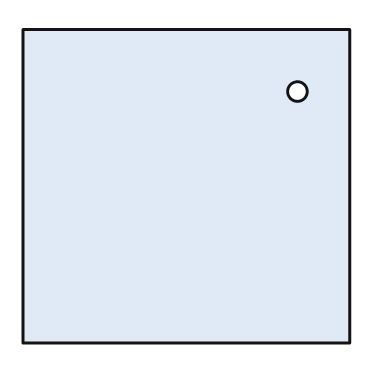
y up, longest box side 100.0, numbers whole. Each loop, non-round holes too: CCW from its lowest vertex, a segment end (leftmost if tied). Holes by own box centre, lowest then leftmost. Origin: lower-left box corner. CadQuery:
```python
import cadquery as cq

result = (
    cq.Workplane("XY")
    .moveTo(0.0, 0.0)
    .lineTo(100.0, 0.0)
    .lineTo(100.0, 96.0)
    .lineTo(0.0, 96.0)
    .close()
    .moveTo(84.0, 77.0)
    .circle(3.0)
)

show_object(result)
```